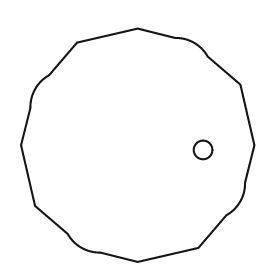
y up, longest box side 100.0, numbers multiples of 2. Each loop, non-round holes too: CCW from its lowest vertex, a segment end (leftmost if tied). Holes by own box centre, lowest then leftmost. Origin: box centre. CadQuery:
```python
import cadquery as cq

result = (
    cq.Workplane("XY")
    .moveTo(0.0, -50.0)
    .lineTo(26.0, -44.0)
    .lineTo(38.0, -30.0)
    .threePointArc((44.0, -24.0), (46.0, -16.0))
    .lineTo(50.0, 0.0)
    .lineTo(44.0, 26.0)
    .lineTo(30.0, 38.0)
    .threePointArc((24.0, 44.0), (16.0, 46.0))
    .lineTo(0.0, 50.0)
    .lineTo(-26.0, 44.0)
    .lineTo(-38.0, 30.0)
    .threePointArc((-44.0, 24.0), (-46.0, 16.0))
    .lineTo(-50.0, 0.0)
    .lineTo(-44.0, -26.0)
    .lineTo(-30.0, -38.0)
    .threePointArc((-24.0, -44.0), (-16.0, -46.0))
    .close()
    .moveTo(28.0, -2.0)
    .circle(4.0)
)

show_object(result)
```